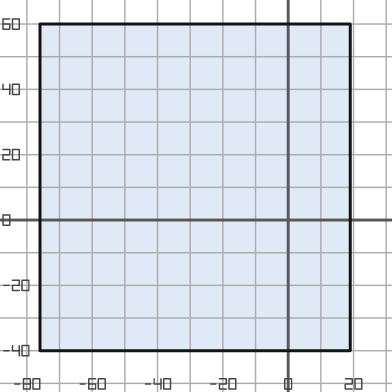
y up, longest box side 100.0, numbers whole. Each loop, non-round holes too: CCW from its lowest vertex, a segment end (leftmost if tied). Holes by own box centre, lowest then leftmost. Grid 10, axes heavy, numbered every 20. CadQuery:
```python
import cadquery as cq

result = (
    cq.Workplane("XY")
    .moveTo(-76.0, -40.0)
    .lineTo(19.0, -40.0)
    .lineTo(19.0, 60.0)
    .lineTo(-76.0, 60.0)
    .close()
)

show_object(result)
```